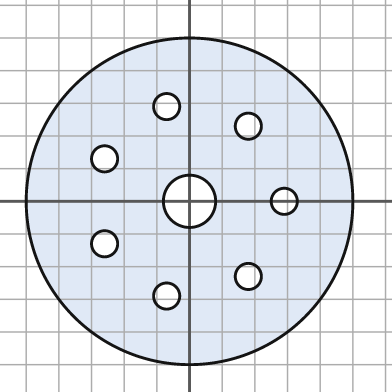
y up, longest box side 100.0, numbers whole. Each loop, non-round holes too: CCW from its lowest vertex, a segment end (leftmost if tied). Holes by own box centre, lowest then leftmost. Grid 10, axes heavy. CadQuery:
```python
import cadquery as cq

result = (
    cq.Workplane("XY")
    .moveTo(0.0, 0.0)
    .circle(50.0)
    .moveTo(-7.0, -29.0)
    .circle(4.0)
    .moveTo(18.0, -23.0)
    .circle(4.0)
    .moveTo(-26.0, -13.0)
    .circle(4.0)
    .moveTo(0.0, 0.0)
    .circle(8.0)
    .moveTo(29.0, 0.0)
    .circle(4.0)
    .moveTo(-26.0, 13.0)
    .circle(4.0)
    .moveTo(18.0, 23.0)
    .circle(4.0)
    .moveTo(-7.0, 29.0)
    .circle(4.0)
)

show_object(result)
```